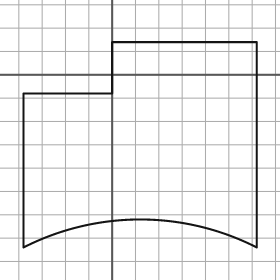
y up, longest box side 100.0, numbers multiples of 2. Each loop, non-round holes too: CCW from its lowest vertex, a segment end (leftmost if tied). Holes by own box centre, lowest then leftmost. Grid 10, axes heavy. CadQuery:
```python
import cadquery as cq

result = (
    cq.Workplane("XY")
    .moveTo(-38.0, -74.0)
    .threePointArc((12.0, -62.0), (62.0, -74.0))
    .lineTo(62.0, 14.0)
    .lineTo(0.0, 14.0)
    .lineTo(0.0, -8.0)
    .lineTo(-38.0, -8.0)
    .close()
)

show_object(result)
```